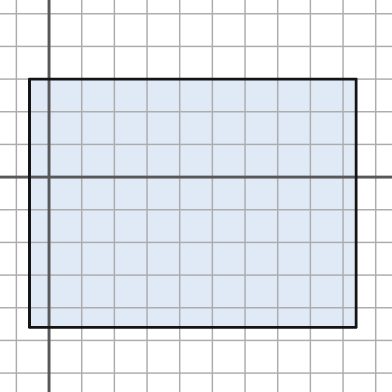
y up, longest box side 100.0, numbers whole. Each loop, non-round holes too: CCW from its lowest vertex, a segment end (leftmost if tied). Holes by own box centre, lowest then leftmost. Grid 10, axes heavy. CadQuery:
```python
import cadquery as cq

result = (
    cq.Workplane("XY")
    .moveTo(-6.0, -46.0)
    .lineTo(94.0, -46.0)
    .lineTo(94.0, 30.0)
    .lineTo(-6.0, 30.0)
    .close()
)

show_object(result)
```